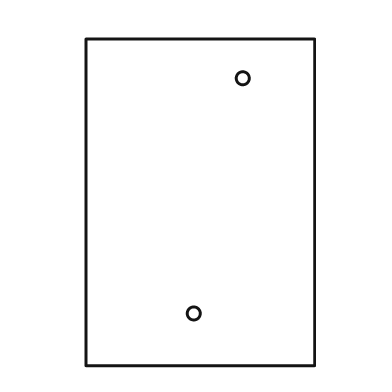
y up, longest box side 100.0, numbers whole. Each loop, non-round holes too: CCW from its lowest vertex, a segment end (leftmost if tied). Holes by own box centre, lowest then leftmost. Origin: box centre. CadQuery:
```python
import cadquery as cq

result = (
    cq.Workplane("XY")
    .moveTo(-35.0, -50.0)
    .lineTo(35.0, -50.0)
    .lineTo(35.0, 50.0)
    .lineTo(-35.0, 50.0)
    .close()
    .moveTo(-2.0, -34.0)
    .circle(2.0)
    .moveTo(13.0, 38.0)
    .circle(2.0)
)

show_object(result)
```